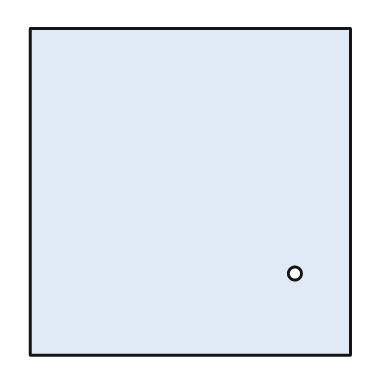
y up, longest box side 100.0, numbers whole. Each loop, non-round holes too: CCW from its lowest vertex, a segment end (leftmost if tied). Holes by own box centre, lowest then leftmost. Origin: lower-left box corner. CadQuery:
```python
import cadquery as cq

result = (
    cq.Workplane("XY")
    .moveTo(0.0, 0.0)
    .lineTo(98.0, 0.0)
    .lineTo(98.0, 100.0)
    .lineTo(0.0, 100.0)
    .close()
    .moveTo(81.0, 25.0)
    .circle(2.0)
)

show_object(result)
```